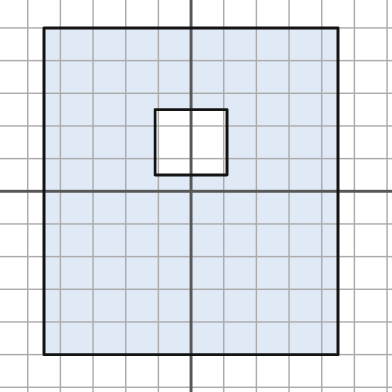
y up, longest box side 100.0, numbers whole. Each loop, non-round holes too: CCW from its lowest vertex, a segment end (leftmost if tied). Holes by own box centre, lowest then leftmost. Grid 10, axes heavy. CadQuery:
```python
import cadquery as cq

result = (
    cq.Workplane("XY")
    .moveTo(-45.0, -50.0)
    .lineTo(45.0, -50.0)
    .lineTo(45.0, 50.0)
    .lineTo(-45.0, 50.0)
    .close()
    .moveTo(-11.0, 5.0)
    .lineTo(11.0, 5.0)
    .lineTo(11.0, 25.0)
    .lineTo(-11.0, 25.0)
    .close()
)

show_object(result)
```